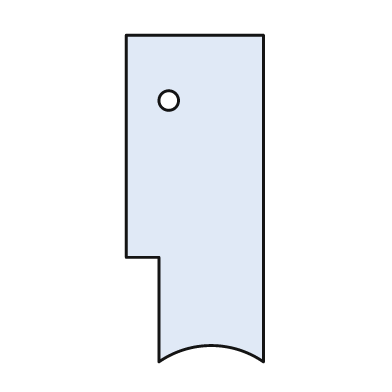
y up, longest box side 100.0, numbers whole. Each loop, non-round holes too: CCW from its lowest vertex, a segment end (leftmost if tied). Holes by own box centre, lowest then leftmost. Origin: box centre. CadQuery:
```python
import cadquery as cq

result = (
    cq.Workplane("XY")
    .moveTo(-11.0, -50.0)
    .threePointArc((5.0, -45.0), (21.0, -50.0))
    .lineTo(21.0, 50.0)
    .lineTo(-21.0, 50.0)
    .lineTo(-21.0, -18.0)
    .lineTo(-11.0, -18.0)
    .close()
    .moveTo(-8.0, 30.0)
    .circle(3.0)
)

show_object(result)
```